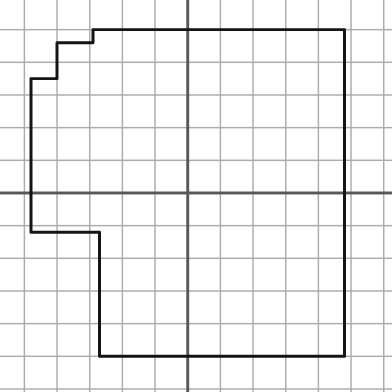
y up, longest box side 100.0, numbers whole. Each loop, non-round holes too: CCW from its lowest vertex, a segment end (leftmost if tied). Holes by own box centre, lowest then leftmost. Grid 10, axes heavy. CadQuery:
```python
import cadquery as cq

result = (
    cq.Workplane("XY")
    .moveTo(-27.0, -50.0)
    .lineTo(48.0, -50.0)
    .lineTo(48.0, 50.0)
    .lineTo(-29.0, 50.0)
    .lineTo(-29.0, 46.0)
    .lineTo(-40.0, 46.0)
    .lineTo(-40.0, 35.0)
    .lineTo(-48.0, 35.0)
    .lineTo(-48.0, -12.0)
    .lineTo(-27.0, -12.0)
    .close()
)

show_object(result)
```